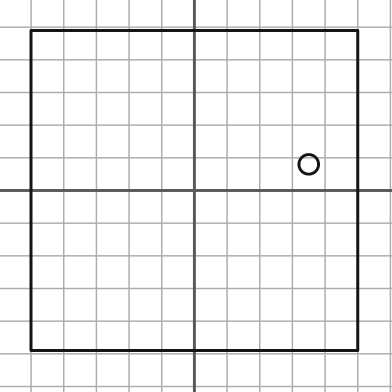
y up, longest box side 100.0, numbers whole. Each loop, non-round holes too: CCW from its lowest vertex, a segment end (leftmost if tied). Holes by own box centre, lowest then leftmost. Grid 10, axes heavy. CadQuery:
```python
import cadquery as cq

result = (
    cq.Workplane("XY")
    .moveTo(-50.0, -49.0)
    .lineTo(50.0, -49.0)
    .lineTo(50.0, 49.0)
    .lineTo(-50.0, 49.0)
    .close()
    .moveTo(35.0, 8.0)
    .circle(3.0)
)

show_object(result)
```